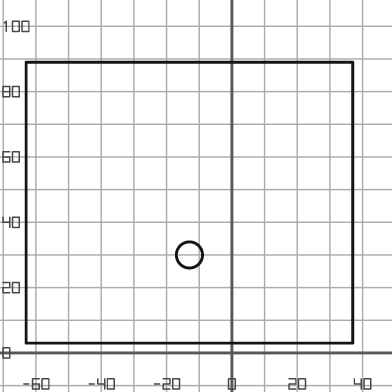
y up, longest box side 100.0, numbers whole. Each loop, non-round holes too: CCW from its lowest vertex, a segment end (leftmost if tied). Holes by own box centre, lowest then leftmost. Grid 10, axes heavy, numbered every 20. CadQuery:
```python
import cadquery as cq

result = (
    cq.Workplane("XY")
    .moveTo(-63.0, 3.0)
    .lineTo(37.0, 3.0)
    .lineTo(37.0, 89.0)
    .lineTo(-63.0, 89.0)
    .close()
    .moveTo(-13.0, 30.0)
    .circle(4.0)
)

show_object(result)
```